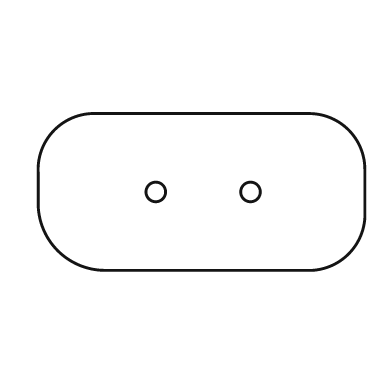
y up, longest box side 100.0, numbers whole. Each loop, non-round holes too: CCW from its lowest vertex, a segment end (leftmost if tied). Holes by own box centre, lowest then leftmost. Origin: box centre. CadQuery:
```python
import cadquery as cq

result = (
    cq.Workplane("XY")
    .moveTo(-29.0, -24.0)
    .lineTo(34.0, -24.0)
    .threePointArc((45.0, -19.0), (50.0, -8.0))
    .lineTo(50.0, 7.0)
    .threePointArc((45.0, 19.0), (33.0, 24.0))
    .lineTo(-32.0, 24.0)
    .threePointArc((-45.0, 19.0), (-50.0, 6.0))
    .lineTo(-50.0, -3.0)
    .threePointArc((-44.0, -18.0), (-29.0, -24.0))
    .close()
    .moveTo(-14.0, 0.0)
    .circle(3.0)
    .moveTo(15.0, 0.0)
    .circle(3.0)
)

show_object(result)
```